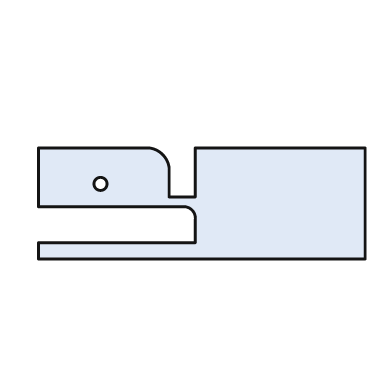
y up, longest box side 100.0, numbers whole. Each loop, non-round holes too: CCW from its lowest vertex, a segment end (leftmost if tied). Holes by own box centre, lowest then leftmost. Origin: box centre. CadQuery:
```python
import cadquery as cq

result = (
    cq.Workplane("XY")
    .moveTo(-50.0, -17.0)
    .lineTo(50.0, -17.0)
    .lineTo(50.0, 17.0)
    .lineTo(-2.0, 17.0)
    .lineTo(-2.0, 2.0)
    .lineTo(-10.0, 2.0)
    .lineTo(-10.0, 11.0)
    .threePointArc((-12.0, 15.0), (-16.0, 17.0))
    .lineTo(-50.0, 17.0)
    .lineTo(-50.0, -1.0)
    .lineTo(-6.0, -1.0)
    .threePointArc((-3.0, -2.0), (-2.0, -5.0))
    .lineTo(-2.0, -12.0)
    .lineTo(-50.0, -12.0)
    .close()
    .moveTo(-31.0, 6.0)
    .circle(2.0)
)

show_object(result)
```